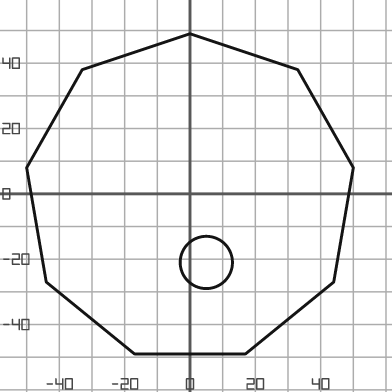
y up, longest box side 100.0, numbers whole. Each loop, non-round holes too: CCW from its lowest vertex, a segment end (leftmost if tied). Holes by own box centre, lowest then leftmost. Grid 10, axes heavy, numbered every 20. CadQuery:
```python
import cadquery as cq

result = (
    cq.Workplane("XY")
    .moveTo(-17.0, -49.0)
    .lineTo(17.0, -49.0)
    .lineTo(44.0, -27.0)
    .lineTo(50.0, 8.0)
    .lineTo(33.0, 38.0)
    .lineTo(0.0, 49.0)
    .lineTo(-33.0, 38.0)
    .lineTo(-50.0, 8.0)
    .lineTo(-44.0, -27.0)
    .close()
    .moveTo(5.0, -21.0)
    .circle(8.0)
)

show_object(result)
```